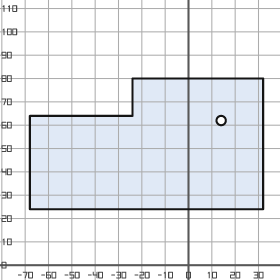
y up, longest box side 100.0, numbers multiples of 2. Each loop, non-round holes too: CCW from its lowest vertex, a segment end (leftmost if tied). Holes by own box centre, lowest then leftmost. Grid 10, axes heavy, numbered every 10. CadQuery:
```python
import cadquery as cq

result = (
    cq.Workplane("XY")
    .moveTo(-68.0, 24.0)
    .lineTo(32.0, 24.0)
    .lineTo(32.0, 80.0)
    .lineTo(-24.0, 80.0)
    .lineTo(-24.0, 64.0)
    .lineTo(-68.0, 64.0)
    .close()
    .moveTo(14.0, 62.0)
    .circle(2.0)
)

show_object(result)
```